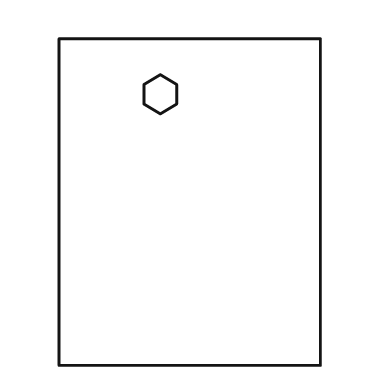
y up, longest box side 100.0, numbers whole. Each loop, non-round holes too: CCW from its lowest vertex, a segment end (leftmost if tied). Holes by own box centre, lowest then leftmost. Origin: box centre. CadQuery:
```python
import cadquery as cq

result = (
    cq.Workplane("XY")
    .moveTo(-40.0, -50.0)
    .lineTo(40.0, -50.0)
    .lineTo(40.0, 50.0)
    .lineTo(-40.0, 50.0)
    .close()
    .moveTo(-9.0, 27.0)
    .lineTo(-4.0, 30.0)
    .lineTo(-4.0, 36.0)
    .lineTo(-9.0, 39.0)
    .lineTo(-14.0, 36.0)
    .lineTo(-14.0, 30.0)
    .close()
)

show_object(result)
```